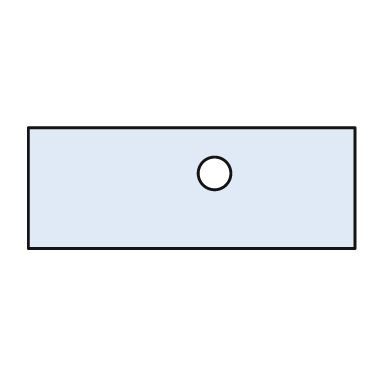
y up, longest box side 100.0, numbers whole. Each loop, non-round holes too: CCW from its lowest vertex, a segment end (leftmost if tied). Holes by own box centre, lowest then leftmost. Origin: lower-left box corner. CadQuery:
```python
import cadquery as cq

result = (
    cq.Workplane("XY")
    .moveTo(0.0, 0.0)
    .lineTo(100.0, 0.0)
    .lineTo(100.0, 37.0)
    .lineTo(0.0, 37.0)
    .close()
    .moveTo(57.0, 23.0)
    .circle(5.0)
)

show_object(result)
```